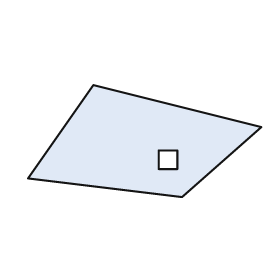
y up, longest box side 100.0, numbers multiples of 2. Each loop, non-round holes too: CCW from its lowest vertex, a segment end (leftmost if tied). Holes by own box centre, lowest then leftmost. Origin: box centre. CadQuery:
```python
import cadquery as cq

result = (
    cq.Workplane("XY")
    .moveTo(16.0, -24.0)
    .lineTo(50.0, 6.0)
    .lineTo(-22.0, 24.0)
    .lineTo(-50.0, -16.0)
    .close()
    .moveTo(6.0, -12.0)
    .lineTo(14.0, -12.0)
    .lineTo(14.0, -4.0)
    .lineTo(6.0, -4.0)
    .close()
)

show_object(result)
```